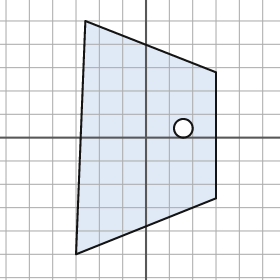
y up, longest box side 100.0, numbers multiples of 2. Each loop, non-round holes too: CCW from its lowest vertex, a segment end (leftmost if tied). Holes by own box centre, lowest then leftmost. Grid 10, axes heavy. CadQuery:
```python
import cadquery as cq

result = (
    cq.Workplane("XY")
    .moveTo(-30.0, -50.0)
    .lineTo(30.0, -26.0)
    .lineTo(30.0, 28.0)
    .lineTo(-26.0, 50.0)
    .close()
    .moveTo(16.0, 4.0)
    .circle(4.0)
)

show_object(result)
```